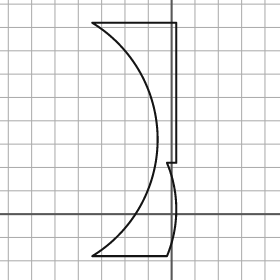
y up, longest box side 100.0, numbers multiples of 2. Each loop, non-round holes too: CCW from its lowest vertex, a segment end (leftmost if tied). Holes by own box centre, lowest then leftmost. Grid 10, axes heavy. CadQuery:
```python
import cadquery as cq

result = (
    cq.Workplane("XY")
    .moveTo(-34.0, -18.0)
    .lineTo(-2.0, -18.0)
    .threePointArc((2.0, 2.0), (-2.0, 22.0))
    .lineTo(2.0, 22.0)
    .lineTo(2.0, 82.0)
    .lineTo(-34.0, 82.0)
    .threePointArc((-6.0, 32.0), (-34.0, -18.0))
    .close()
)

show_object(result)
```